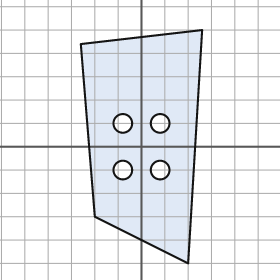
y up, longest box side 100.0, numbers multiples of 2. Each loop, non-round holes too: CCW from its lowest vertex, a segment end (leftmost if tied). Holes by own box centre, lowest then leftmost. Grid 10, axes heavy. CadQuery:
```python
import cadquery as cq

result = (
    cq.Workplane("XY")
    .moveTo(20.0, -50.0)
    .lineTo(26.0, 50.0)
    .lineTo(-26.0, 44.0)
    .lineTo(-20.0, -30.0)
    .close()
    .moveTo(-8.0, -10.0)
    .circle(4.0)
    .moveTo(8.0, -10.0)
    .circle(4.0)
    .moveTo(-8.0, 10.0)
    .circle(4.0)
    .moveTo(8.0, 10.0)
    .circle(4.0)
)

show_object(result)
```